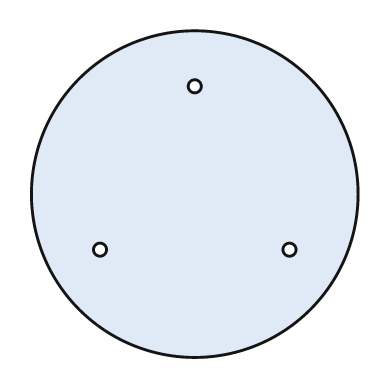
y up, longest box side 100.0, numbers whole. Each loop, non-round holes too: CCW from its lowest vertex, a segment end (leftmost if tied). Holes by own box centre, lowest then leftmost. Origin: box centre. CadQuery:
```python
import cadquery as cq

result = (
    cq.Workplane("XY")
    .moveTo(0.0, 0.0)
    .circle(50.0)
    .moveTo(-29.0, -17.0)
    .circle(2.0)
    .moveTo(29.0, -17.0)
    .circle(2.0)
    .moveTo(0.0, 33.0)
    .circle(2.0)
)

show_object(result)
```